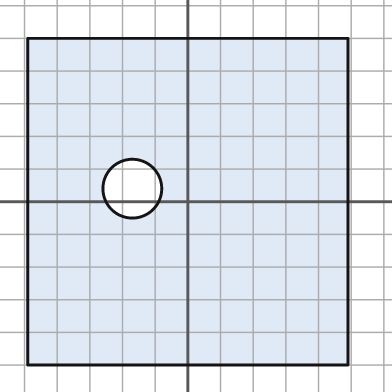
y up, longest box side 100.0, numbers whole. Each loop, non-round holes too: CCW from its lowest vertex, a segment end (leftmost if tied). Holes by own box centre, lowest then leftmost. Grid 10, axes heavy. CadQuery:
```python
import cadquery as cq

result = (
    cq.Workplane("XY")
    .moveTo(-49.0, -50.0)
    .lineTo(49.0, -50.0)
    .lineTo(49.0, 50.0)
    .lineTo(-49.0, 50.0)
    .close()
    .moveTo(-17.0, 4.0)
    .circle(9.0)
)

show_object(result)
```